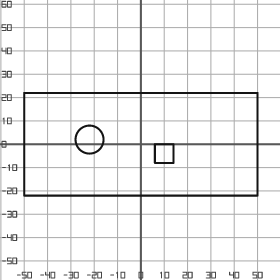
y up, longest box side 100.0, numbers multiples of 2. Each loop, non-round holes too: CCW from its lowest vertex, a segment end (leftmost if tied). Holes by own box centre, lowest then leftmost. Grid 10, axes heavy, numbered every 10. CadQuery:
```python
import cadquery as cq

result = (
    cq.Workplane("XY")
    .moveTo(-50.0, -22.0)
    .lineTo(50.0, -22.0)
    .lineTo(50.0, 22.0)
    .lineTo(-50.0, 22.0)
    .close()
    .moveTo(6.0, -8.0)
    .lineTo(14.0, -8.0)
    .lineTo(14.0, 0.0)
    .lineTo(6.0, 0.0)
    .close()
    .moveTo(-22.0, 2.0)
    .circle(6.0)
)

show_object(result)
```